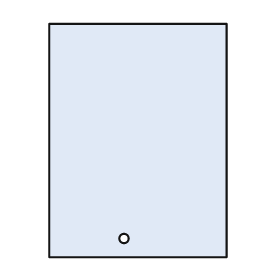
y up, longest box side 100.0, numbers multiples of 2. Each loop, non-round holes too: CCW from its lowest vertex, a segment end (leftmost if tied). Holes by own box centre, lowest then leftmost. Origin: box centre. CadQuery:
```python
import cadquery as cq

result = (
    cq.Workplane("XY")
    .moveTo(-38.0, -50.0)
    .lineTo(38.0, -50.0)
    .lineTo(38.0, 50.0)
    .lineTo(-38.0, 50.0)
    .close()
    .moveTo(-6.0, -42.0)
    .circle(2.0)
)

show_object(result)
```